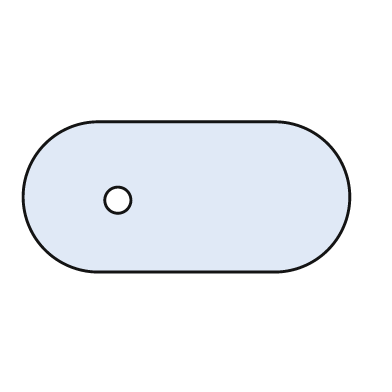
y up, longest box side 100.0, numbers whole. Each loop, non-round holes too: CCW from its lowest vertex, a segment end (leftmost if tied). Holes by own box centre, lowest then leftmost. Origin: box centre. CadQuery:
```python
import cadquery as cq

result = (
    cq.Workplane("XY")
    .moveTo(-27.0, -23.0)
    .lineTo(27.0, -23.0)
    .threePointArc((50.0, 0.0), (27.0, 23.0))
    .lineTo(-27.0, 23.0)
    .threePointArc((-50.0, 0.0), (-27.0, -23.0))
    .close()
    .moveTo(-21.0, -1.0)
    .circle(4.0)
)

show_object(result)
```